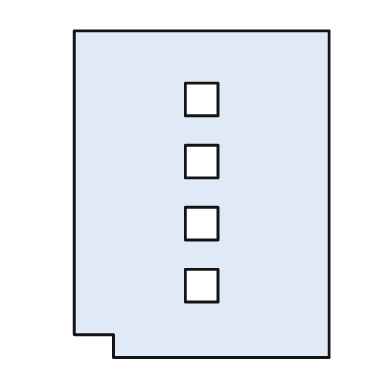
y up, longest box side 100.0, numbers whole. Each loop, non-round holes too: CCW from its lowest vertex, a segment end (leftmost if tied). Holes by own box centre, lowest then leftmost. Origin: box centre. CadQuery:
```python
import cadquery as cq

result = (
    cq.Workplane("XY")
    .moveTo(-27.0, -50.0)
    .lineTo(39.0, -50.0)
    .lineTo(39.0, 50.0)
    .lineTo(-39.0, 50.0)
    .lineTo(-39.0, -43.0)
    .lineTo(-27.0, -43.0)
    .close()
    .moveTo(-5.0, -33.0)
    .lineTo(5.0, -33.0)
    .lineTo(5.0, -23.0)
    .lineTo(-5.0, -23.0)
    .close()
    .moveTo(-5.0, -14.0)
    .lineTo(5.0, -14.0)
    .lineTo(5.0, -4.0)
    .lineTo(-5.0, -4.0)
    .close()
    .moveTo(-5.0, 5.0)
    .lineTo(5.0, 5.0)
    .lineTo(5.0, 15.0)
    .lineTo(-5.0, 15.0)
    .close()
    .moveTo(-5.0, 24.0)
    .lineTo(5.0, 24.0)
    .lineTo(5.0, 34.0)
    .lineTo(-5.0, 34.0)
    .close()
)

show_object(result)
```